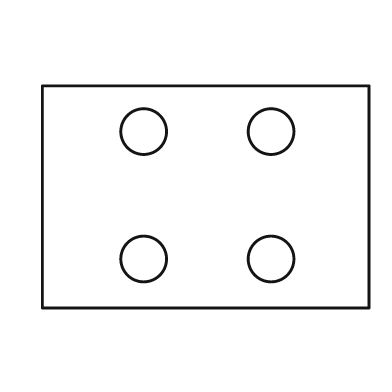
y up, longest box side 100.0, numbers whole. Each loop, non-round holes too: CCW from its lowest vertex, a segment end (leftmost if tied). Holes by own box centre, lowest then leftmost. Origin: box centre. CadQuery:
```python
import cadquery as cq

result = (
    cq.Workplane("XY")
    .moveTo(-50.0, -34.0)
    .lineTo(50.0, -34.0)
    .lineTo(50.0, 34.0)
    .lineTo(-50.0, 34.0)
    .close()
    .moveTo(-19.0, -19.0)
    .circle(7.0)
    .moveTo(20.0, -19.0)
    .circle(7.0)
    .moveTo(-19.0, 20.0)
    .circle(7.0)
    .moveTo(20.0, 20.0)
    .circle(7.0)
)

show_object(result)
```